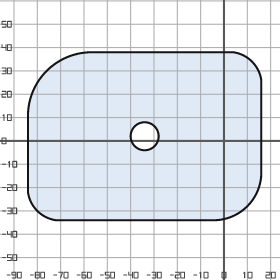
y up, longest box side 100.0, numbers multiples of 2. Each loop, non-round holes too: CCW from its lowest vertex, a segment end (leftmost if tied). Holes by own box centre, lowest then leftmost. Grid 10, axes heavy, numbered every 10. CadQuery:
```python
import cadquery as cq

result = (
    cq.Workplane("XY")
    .moveTo(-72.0, -34.0)
    .lineTo(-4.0, -34.0)
    .threePointArc((10.0, -28.0), (16.0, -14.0))
    .lineTo(16.0, 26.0)
    .threePointArc((12.0, 34.0), (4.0, 38.0))
    .lineTo(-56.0, 38.0)
    .threePointArc((-76.0, 30.0), (-84.0, 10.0))
    .lineTo(-84.0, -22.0)
    .threePointArc((-80.0, -30.0), (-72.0, -34.0))
    .close()
    .moveTo(-34.0, 2.0)
    .circle(6.0)
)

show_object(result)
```